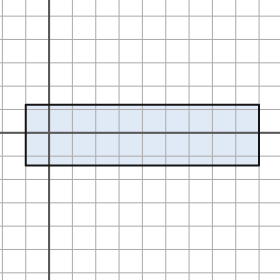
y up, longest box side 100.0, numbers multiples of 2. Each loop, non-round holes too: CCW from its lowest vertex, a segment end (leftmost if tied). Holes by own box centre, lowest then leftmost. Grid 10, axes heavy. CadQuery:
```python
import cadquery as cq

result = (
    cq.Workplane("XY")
    .moveTo(-10.0, -14.0)
    .lineTo(90.0, -14.0)
    .lineTo(90.0, 12.0)
    .lineTo(-10.0, 12.0)
    .close()
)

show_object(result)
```